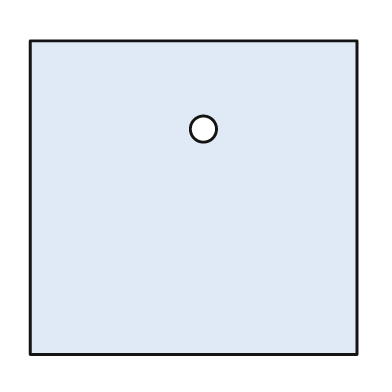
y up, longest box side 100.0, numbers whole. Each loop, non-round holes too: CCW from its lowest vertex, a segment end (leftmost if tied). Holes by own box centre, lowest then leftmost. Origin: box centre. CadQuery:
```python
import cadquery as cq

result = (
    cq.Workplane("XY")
    .moveTo(-50.0, -48.0)
    .lineTo(50.0, -48.0)
    .lineTo(50.0, 48.0)
    .lineTo(-50.0, 48.0)
    .close()
    .moveTo(3.0, 21.0)
    .circle(4.0)
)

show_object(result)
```